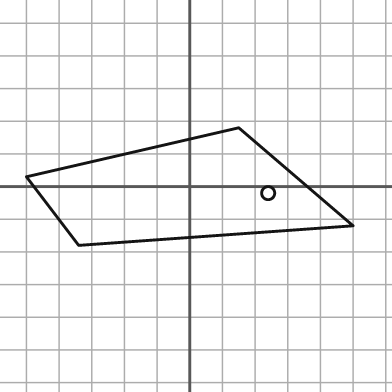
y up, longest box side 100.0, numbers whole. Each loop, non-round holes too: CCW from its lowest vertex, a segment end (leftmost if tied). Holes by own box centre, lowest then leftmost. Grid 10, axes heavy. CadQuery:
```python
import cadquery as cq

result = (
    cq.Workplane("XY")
    .moveTo(-34.0, -18.0)
    .lineTo(50.0, -12.0)
    .lineTo(15.0, 18.0)
    .lineTo(-50.0, 3.0)
    .close()
    .moveTo(24.0, -2.0)
    .circle(2.0)
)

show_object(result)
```